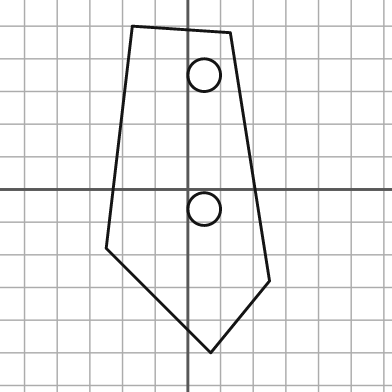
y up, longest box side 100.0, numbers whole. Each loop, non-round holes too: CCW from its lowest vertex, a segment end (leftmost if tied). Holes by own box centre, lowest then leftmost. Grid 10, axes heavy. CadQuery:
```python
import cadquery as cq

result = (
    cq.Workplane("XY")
    .moveTo(7.0, -50.0)
    .lineTo(25.0, -28.0)
    .lineTo(13.0, 48.0)
    .lineTo(-17.0, 50.0)
    .lineTo(-25.0, -18.0)
    .close()
    .moveTo(5.0, -6.0)
    .circle(5.0)
    .moveTo(5.0, 35.0)
    .circle(5.0)
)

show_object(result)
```